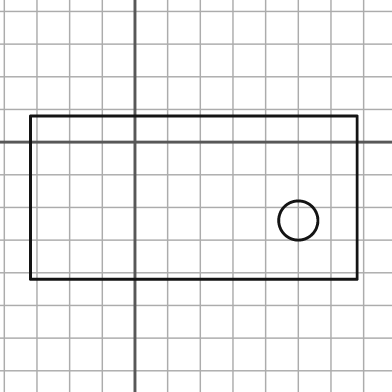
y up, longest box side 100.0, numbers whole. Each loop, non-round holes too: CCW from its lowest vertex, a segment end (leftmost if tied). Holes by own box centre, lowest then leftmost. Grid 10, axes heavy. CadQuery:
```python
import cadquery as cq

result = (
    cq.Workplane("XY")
    .moveTo(-32.0, -42.0)
    .lineTo(68.0, -42.0)
    .lineTo(68.0, 8.0)
    .lineTo(-32.0, 8.0)
    .close()
    .moveTo(50.0, -24.0)
    .circle(6.0)
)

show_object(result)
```